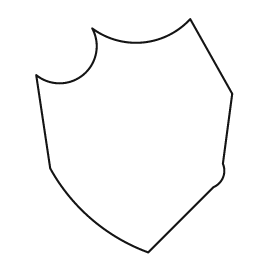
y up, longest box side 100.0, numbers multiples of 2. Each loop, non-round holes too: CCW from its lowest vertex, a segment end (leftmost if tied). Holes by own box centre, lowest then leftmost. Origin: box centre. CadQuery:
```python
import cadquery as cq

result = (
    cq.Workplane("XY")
    .moveTo(6.0, -50.0)
    .lineTo(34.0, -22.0)
    .threePointArc((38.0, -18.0), (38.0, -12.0))
    .lineTo(42.0, 18.0)
    .lineTo(24.0, 50.0)
    .threePointArc((4.0, 40.0), (-18.0, 46.0))
    .threePointArc((-22.0, 26.0), (-42.0, 26.0))
    .lineTo(-36.0, -14.0)
    .threePointArc((-18.0, -36.0), (6.0, -50.0))
    .close()
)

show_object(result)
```